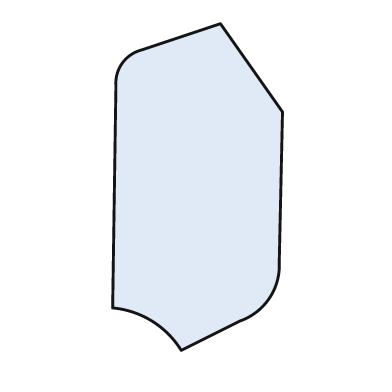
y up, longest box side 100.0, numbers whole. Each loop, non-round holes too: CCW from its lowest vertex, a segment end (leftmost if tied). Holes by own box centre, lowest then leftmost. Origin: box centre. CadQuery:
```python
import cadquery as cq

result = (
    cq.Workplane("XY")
    .moveTo(-5.0, -50.0)
    .lineTo(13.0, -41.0)
    .threePointArc((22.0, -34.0), (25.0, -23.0))
    .lineTo(26.0, 23.0)
    .lineTo(7.0, 50.0)
    .lineTo(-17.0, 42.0)
    .threePointArc((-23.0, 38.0), (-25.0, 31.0))
    .lineTo(-26.0, -37.0)
    .threePointArc((-14.0, -41.0), (-5.0, -50.0))
    .close()
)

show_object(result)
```